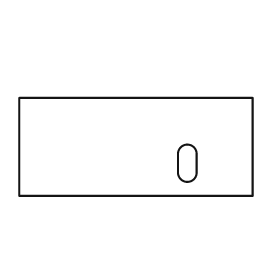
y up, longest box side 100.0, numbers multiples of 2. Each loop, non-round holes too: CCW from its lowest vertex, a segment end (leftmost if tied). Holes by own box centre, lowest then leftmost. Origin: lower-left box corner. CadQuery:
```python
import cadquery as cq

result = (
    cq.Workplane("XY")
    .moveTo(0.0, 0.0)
    .lineTo(100.0, 0.0)
    .lineTo(100.0, 42.0)
    .lineTo(0.0, 42.0)
    .close()
    .moveTo(68.0, 10.0)
    .threePointArc((72.0, 6.0), (76.0, 10.0))
    .lineTo(76.0, 18.0)
    .threePointArc((72.0, 22.0), (68.0, 18.0))
    .close()
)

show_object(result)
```